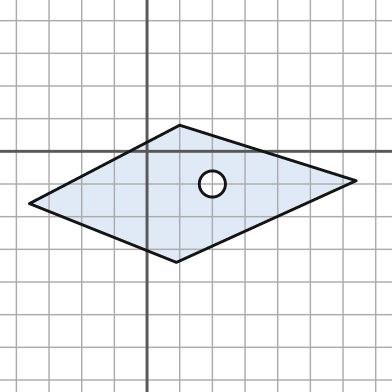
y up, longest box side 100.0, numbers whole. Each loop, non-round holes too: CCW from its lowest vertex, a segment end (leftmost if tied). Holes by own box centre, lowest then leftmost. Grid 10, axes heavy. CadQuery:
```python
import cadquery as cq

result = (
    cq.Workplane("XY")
    .moveTo(9.0, -34.0)
    .lineTo(64.0, -9.0)
    .lineTo(10.0, 8.0)
    .lineTo(-36.0, -16.0)
    .close()
    .moveTo(20.0, -10.0)
    .circle(4.0)
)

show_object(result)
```